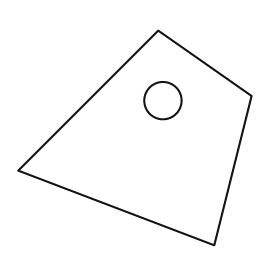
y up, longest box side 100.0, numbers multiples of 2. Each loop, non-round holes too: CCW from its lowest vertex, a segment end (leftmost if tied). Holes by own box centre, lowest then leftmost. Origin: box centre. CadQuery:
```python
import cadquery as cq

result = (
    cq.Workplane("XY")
    .moveTo(34.0, -46.0)
    .lineTo(50.0, 18.0)
    .lineTo(10.0, 46.0)
    .lineTo(-50.0, -14.0)
    .close()
    .moveTo(12.0, 16.0)
    .circle(8.0)
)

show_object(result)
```